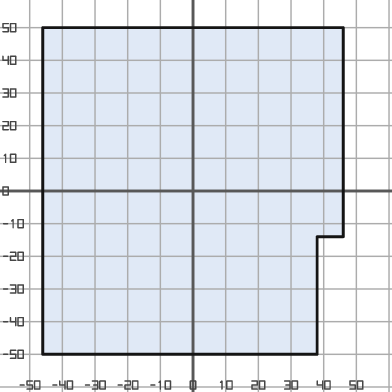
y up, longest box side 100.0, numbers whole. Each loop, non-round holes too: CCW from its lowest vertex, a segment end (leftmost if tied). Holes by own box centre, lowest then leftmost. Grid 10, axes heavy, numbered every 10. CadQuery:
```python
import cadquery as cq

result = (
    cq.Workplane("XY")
    .moveTo(-46.0, -50.0)
    .lineTo(38.0, -50.0)
    .lineTo(38.0, -14.0)
    .lineTo(46.0, -14.0)
    .lineTo(46.0, 50.0)
    .lineTo(-46.0, 50.0)
    .close()
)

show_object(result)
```